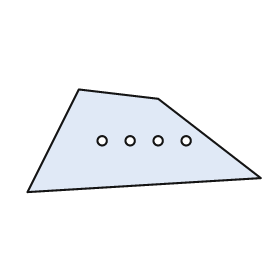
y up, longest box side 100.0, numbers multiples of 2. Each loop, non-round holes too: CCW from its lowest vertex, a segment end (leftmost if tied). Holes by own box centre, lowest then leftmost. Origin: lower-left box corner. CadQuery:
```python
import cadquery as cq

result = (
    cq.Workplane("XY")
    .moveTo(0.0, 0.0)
    .lineTo(100.0, 6.0)
    .lineTo(56.0, 40.0)
    .lineTo(22.0, 44.0)
    .close()
    .moveTo(32.0, 22.0)
    .circle(2.0)
    .moveTo(44.0, 22.0)
    .circle(2.0)
    .moveTo(56.0, 22.0)
    .circle(2.0)
    .moveTo(68.0, 22.0)
    .circle(2.0)
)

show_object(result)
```